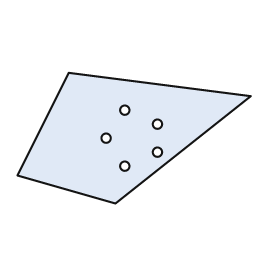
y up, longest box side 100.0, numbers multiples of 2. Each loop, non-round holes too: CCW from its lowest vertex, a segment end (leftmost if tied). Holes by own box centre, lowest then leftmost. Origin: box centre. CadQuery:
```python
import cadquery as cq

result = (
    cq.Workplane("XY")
    .moveTo(-8.0, -28.0)
    .lineTo(50.0, 18.0)
    .lineTo(-28.0, 28.0)
    .lineTo(-50.0, -16.0)
    .close()
    .moveTo(-4.0, -12.0)
    .circle(2.0)
    .moveTo(10.0, -6.0)
    .circle(2.0)
    .moveTo(-12.0, 0.0)
    .circle(2.0)
    .moveTo(10.0, 6.0)
    .circle(2.0)
    .moveTo(-4.0, 12.0)
    .circle(2.0)
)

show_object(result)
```